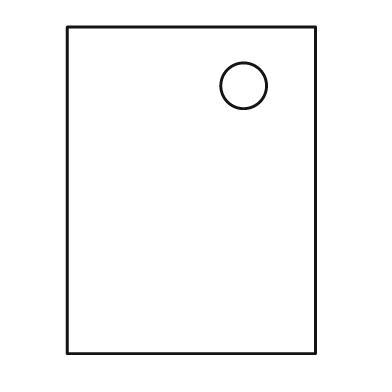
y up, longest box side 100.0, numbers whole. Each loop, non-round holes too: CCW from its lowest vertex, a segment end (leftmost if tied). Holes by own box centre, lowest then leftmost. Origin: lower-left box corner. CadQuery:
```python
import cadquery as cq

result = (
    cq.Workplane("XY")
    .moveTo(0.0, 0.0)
    .lineTo(76.0, 0.0)
    .lineTo(76.0, 100.0)
    .lineTo(0.0, 100.0)
    .close()
    .moveTo(54.0, 82.0)
    .circle(7.0)
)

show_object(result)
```